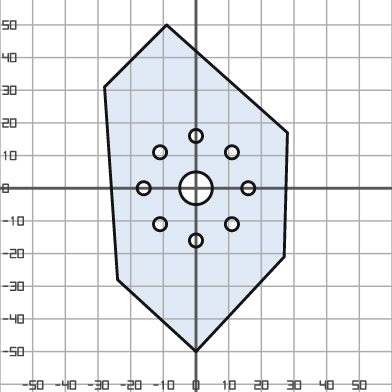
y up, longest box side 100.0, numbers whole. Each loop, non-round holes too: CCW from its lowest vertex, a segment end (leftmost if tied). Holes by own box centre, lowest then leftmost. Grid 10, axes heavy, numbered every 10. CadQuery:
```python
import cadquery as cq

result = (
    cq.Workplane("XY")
    .moveTo(0.0, -50.0)
    .lineTo(27.0, -21.0)
    .lineTo(28.0, 17.0)
    .lineTo(-9.0, 50.0)
    .lineTo(-28.0, 31.0)
    .lineTo(-24.0, -28.0)
    .close()
    .moveTo(0.0, -16.0)
    .circle(2.0)
    .moveTo(-11.0, -11.0)
    .circle(2.0)
    .moveTo(11.0, -11.0)
    .circle(2.0)
    .moveTo(-16.0, 0.0)
    .circle(2.0)
    .moveTo(0.0, 0.0)
    .circle(5.0)
    .moveTo(16.0, 0.0)
    .circle(2.0)
    .moveTo(-11.0, 11.0)
    .circle(2.0)
    .moveTo(11.0, 11.0)
    .circle(2.0)
    .moveTo(0.0, 16.0)
    .circle(2.0)
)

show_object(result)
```